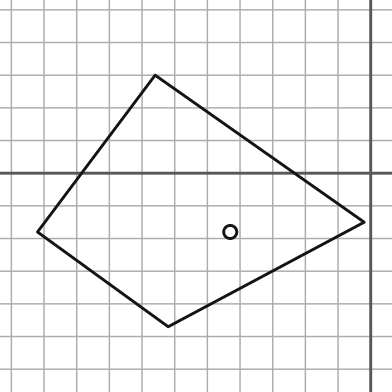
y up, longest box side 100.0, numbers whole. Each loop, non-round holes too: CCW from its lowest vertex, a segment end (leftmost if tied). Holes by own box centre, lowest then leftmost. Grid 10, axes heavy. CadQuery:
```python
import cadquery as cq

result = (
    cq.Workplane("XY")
    .moveTo(-62.0, -47.0)
    .lineTo(-2.0, -15.0)
    .lineTo(-66.0, 30.0)
    .lineTo(-102.0, -18.0)
    .close()
    .moveTo(-43.0, -18.0)
    .circle(2.0)
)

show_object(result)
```